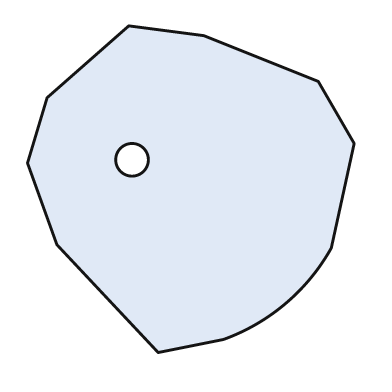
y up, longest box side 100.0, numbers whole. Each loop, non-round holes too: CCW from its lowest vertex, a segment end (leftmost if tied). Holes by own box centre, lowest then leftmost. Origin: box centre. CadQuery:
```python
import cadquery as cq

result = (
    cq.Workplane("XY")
    .moveTo(-10.0, -50.0)
    .lineTo(10.0, -46.0)
    .threePointArc((29.0, -35.0), (43.0, -18.0))
    .lineTo(50.0, 14.0)
    .lineTo(39.0, 33.0)
    .lineTo(4.0, 47.0)
    .lineTo(-19.0, 50.0)
    .lineTo(-44.0, 28.0)
    .lineTo(-50.0, 8.0)
    .lineTo(-41.0, -17.0)
    .close()
    .moveTo(-18.0, 9.0)
    .circle(5.0)
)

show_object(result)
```